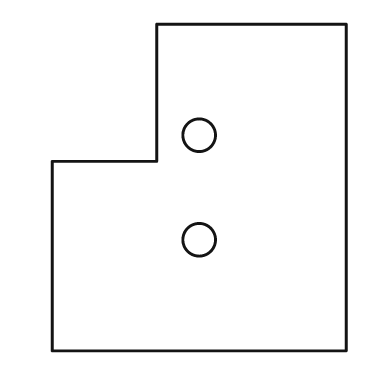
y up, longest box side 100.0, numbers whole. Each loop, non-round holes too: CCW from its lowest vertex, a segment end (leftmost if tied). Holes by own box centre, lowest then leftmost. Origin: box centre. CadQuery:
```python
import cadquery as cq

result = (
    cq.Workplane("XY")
    .moveTo(-45.0, -50.0)
    .lineTo(45.0, -50.0)
    .lineTo(45.0, 50.0)
    .lineTo(-13.0, 50.0)
    .lineTo(-13.0, 8.0)
    .lineTo(-45.0, 8.0)
    .close()
    .moveTo(0.0, -16.0)
    .circle(5.0)
    .moveTo(0.0, 16.0)
    .circle(5.0)
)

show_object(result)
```